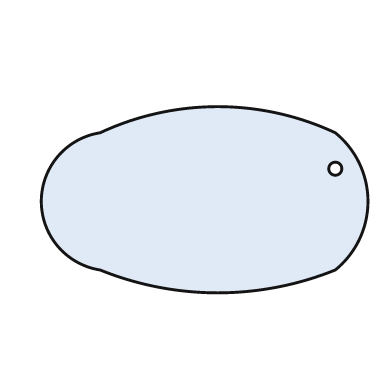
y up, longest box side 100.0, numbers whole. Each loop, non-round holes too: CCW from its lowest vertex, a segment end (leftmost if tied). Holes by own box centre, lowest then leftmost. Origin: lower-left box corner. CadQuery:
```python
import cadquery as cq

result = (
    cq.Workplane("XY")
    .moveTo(18.0, 7.0)
    .threePointArc((54.0, 0.0), (90.0, 7.0))
    .threePointArc((100.0, 28.0), (90.0, 49.0))
    .threePointArc((54.0, 57.0), (18.0, 49.0))
    .threePointArc((0.0, 28.0), (18.0, 7.0))
    .close()
    .moveTo(90.0, 38.0)
    .circle(2.0)
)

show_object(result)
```